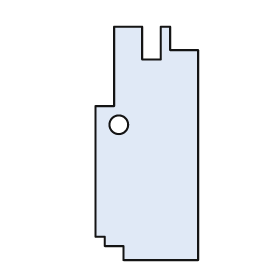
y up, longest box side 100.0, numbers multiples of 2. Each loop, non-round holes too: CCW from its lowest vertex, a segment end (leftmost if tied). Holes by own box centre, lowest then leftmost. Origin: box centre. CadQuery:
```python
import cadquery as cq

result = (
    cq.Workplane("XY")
    .moveTo(-10.0, -50.0)
    .lineTo(22.0, -50.0)
    .lineTo(22.0, 40.0)
    .lineTo(10.0, 40.0)
    .lineTo(10.0, 50.0)
    .lineTo(6.0, 50.0)
    .lineTo(6.0, 36.0)
    .lineTo(-2.0, 36.0)
    .lineTo(-2.0, 50.0)
    .lineTo(-14.0, 50.0)
    .lineTo(-14.0, 16.0)
    .lineTo(-22.0, 16.0)
    .lineTo(-22.0, -40.0)
    .lineTo(-18.0, -40.0)
    .lineTo(-18.0, -44.0)
    .lineTo(-10.0, -44.0)
    .close()
    .moveTo(-12.0, 8.0)
    .circle(4.0)
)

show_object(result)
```